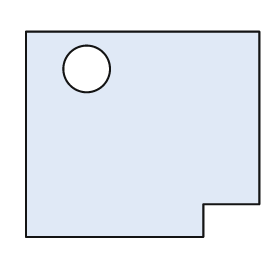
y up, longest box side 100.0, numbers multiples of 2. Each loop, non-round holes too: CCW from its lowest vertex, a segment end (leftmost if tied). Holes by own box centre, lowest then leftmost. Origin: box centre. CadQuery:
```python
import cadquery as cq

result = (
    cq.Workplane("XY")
    .moveTo(-50.0, -44.0)
    .lineTo(26.0, -44.0)
    .lineTo(26.0, -30.0)
    .lineTo(50.0, -30.0)
    .lineTo(50.0, 44.0)
    .lineTo(-50.0, 44.0)
    .close()
    .moveTo(-24.0, 28.0)
    .circle(10.0)
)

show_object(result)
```